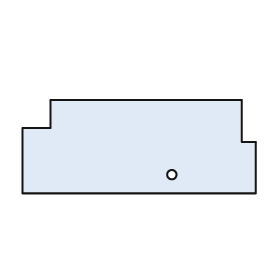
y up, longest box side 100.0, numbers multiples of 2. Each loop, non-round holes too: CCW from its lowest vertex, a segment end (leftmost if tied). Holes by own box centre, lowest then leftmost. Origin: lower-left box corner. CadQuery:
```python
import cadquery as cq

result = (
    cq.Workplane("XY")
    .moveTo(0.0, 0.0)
    .lineTo(100.0, 0.0)
    .lineTo(100.0, 22.0)
    .lineTo(94.0, 22.0)
    .lineTo(94.0, 40.0)
    .lineTo(12.0, 40.0)
    .lineTo(12.0, 28.0)
    .lineTo(0.0, 28.0)
    .close()
    .moveTo(64.0, 8.0)
    .circle(2.0)
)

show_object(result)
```